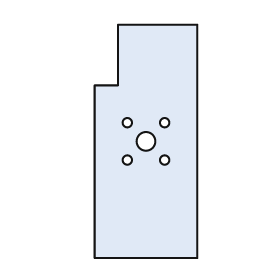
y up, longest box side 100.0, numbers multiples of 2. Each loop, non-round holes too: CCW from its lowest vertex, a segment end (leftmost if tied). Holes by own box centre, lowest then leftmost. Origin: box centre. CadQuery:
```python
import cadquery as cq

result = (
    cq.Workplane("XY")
    .moveTo(-22.0, -50.0)
    .lineTo(22.0, -50.0)
    .lineTo(22.0, 50.0)
    .lineTo(-12.0, 50.0)
    .lineTo(-12.0, 24.0)
    .lineTo(-22.0, 24.0)
    .close()
    .moveTo(-8.0, -8.0)
    .circle(2.0)
    .moveTo(8.0, -8.0)
    .circle(2.0)
    .moveTo(0.0, 0.0)
    .circle(4.0)
    .moveTo(-8.0, 8.0)
    .circle(2.0)
    .moveTo(8.0, 8.0)
    .circle(2.0)
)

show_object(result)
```